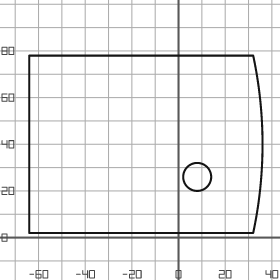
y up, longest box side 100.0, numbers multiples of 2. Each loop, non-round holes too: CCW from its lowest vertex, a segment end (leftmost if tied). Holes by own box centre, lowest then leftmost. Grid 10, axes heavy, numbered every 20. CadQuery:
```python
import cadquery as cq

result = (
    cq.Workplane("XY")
    .moveTo(-64.0, 2.0)
    .lineTo(32.0, 2.0)
    .threePointArc((36.0, 40.0), (32.0, 78.0))
    .lineTo(-64.0, 78.0)
    .close()
    .moveTo(8.0, 26.0)
    .circle(6.0)
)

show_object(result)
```